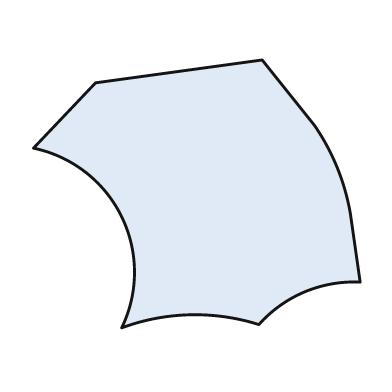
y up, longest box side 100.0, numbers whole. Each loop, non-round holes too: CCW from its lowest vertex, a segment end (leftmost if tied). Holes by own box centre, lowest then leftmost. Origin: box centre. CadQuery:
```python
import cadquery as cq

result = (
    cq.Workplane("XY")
    .moveTo(-23.0, -41.0)
    .threePointArc((-2.0, -37.0), (19.0, -40.0))
    .threePointArc((33.0, -30.0), (50.0, -27.0))
    .lineTo(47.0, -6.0)
    .threePointArc((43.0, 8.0), (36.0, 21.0))
    .lineTo(20.0, 41.0)
    .lineTo(-31.0, 34.0)
    .lineTo(-50.0, 14.0)
    .threePointArc((-23.0, -7.0), (-23.0, -41.0))
    .close()
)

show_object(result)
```